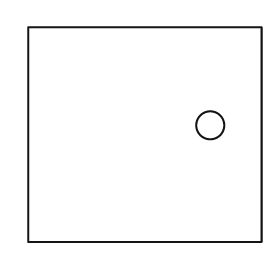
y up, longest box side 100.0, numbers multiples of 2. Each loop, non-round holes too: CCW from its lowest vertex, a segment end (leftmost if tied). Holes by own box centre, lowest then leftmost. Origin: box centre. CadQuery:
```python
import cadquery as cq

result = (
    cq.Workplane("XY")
    .moveTo(-50.0, -46.0)
    .lineTo(50.0, -46.0)
    .lineTo(50.0, 46.0)
    .lineTo(-50.0, 46.0)
    .close()
    .moveTo(28.0, 4.0)
    .circle(6.0)
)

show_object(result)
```